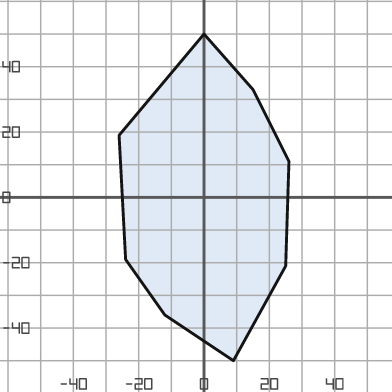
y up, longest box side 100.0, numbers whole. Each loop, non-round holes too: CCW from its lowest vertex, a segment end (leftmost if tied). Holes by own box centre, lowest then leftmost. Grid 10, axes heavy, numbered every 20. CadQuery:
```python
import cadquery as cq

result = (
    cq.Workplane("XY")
    .moveTo(9.0, -50.0)
    .lineTo(25.0, -21.0)
    .lineTo(26.0, 11.0)
    .lineTo(15.0, 33.0)
    .lineTo(0.0, 50.0)
    .lineTo(-26.0, 19.0)
    .lineTo(-24.0, -19.0)
    .lineTo(-12.0, -36.0)
    .close()
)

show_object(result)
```